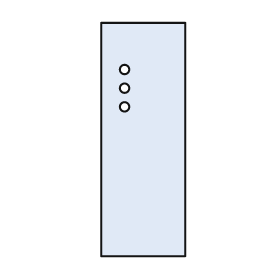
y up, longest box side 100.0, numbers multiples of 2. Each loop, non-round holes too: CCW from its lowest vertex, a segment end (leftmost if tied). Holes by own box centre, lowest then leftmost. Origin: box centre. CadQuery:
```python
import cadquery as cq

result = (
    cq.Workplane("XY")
    .moveTo(-18.0, -50.0)
    .lineTo(18.0, -50.0)
    .lineTo(18.0, 50.0)
    .lineTo(-18.0, 50.0)
    .close()
    .moveTo(-8.0, 14.0)
    .circle(2.0)
    .moveTo(-8.0, 22.0)
    .circle(2.0)
    .moveTo(-8.0, 30.0)
    .circle(2.0)
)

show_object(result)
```